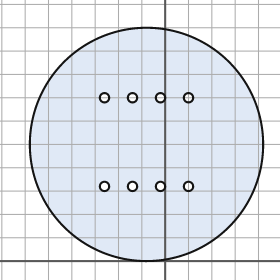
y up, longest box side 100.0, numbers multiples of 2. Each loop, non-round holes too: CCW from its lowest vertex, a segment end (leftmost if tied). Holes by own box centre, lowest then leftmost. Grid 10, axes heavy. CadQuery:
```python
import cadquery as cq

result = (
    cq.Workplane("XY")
    .moveTo(-8.0, 50.0)
    .circle(50.0)
    .moveTo(-26.0, 32.0)
    .circle(2.0)
    .moveTo(-14.0, 32.0)
    .circle(2.0)
    .moveTo(-2.0, 32.0)
    .circle(2.0)
    .moveTo(10.0, 32.0)
    .circle(2.0)
    .moveTo(-26.0, 70.0)
    .circle(2.0)
    .moveTo(-14.0, 70.0)
    .circle(2.0)
    .moveTo(-2.0, 70.0)
    .circle(2.0)
    .moveTo(10.0, 70.0)
    .circle(2.0)
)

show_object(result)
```